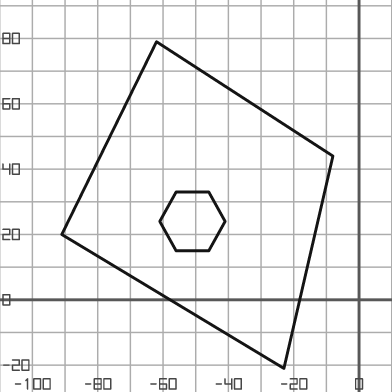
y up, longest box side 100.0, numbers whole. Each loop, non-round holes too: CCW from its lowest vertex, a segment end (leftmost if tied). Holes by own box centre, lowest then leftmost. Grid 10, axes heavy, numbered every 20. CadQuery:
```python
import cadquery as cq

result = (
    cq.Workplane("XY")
    .moveTo(-23.0, -21.0)
    .lineTo(-8.0, 44.0)
    .lineTo(-62.0, 79.0)
    .lineTo(-91.0, 20.0)
    .close()
    .moveTo(-56.0, 15.0)
    .lineTo(-46.0, 15.0)
    .lineTo(-41.0, 24.0)
    .lineTo(-46.0, 33.0)
    .lineTo(-56.0, 33.0)
    .lineTo(-61.0, 24.0)
    .close()
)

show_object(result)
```